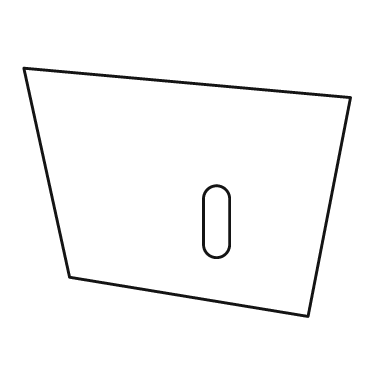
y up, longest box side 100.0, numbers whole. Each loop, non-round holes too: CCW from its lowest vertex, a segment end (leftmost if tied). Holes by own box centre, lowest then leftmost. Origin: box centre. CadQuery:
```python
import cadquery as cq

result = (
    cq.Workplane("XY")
    .moveTo(37.0, -38.0)
    .lineTo(50.0, 29.0)
    .lineTo(-50.0, 38.0)
    .lineTo(-36.0, -26.0)
    .close()
    .moveTo(5.0, -16.0)
    .threePointArc((9.0, -20.0), (13.0, -16.0))
    .lineTo(13.0, -2.0)
    .threePointArc((9.0, 2.0), (5.0, -2.0))
    .close()
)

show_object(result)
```